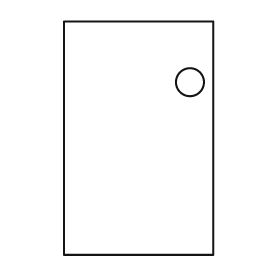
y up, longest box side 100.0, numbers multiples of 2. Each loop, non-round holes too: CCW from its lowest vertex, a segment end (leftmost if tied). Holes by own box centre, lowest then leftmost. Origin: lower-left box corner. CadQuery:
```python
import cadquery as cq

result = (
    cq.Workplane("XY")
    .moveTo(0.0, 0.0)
    .lineTo(64.0, 0.0)
    .lineTo(64.0, 100.0)
    .lineTo(0.0, 100.0)
    .close()
    .moveTo(54.0, 74.0)
    .circle(6.0)
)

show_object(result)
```